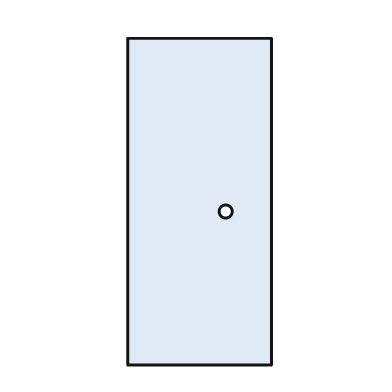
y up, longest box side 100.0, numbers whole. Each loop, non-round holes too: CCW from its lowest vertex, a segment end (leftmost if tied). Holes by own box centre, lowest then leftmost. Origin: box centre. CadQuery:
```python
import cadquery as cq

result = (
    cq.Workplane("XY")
    .moveTo(-22.0, -50.0)
    .lineTo(22.0, -50.0)
    .lineTo(22.0, 50.0)
    .lineTo(-22.0, 50.0)
    .close()
    .moveTo(8.0, -3.0)
    .circle(2.0)
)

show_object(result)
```